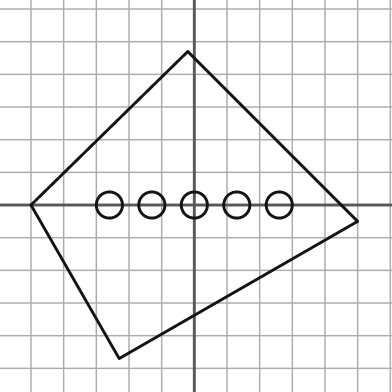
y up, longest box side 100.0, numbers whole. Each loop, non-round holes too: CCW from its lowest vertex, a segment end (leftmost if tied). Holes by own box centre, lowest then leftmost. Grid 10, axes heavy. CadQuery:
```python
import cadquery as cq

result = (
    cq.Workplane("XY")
    .moveTo(-23.0, -47.0)
    .lineTo(50.0, -5.0)
    .lineTo(-2.0, 47.0)
    .lineTo(-50.0, 0.0)
    .close()
    .moveTo(-26.0, 0.0)
    .circle(4.0)
    .moveTo(-13.0, 0.0)
    .circle(4.0)
    .moveTo(0.0, 0.0)
    .circle(4.0)
    .moveTo(13.0, 0.0)
    .circle(4.0)
    .moveTo(26.0, 0.0)
    .circle(4.0)
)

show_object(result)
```